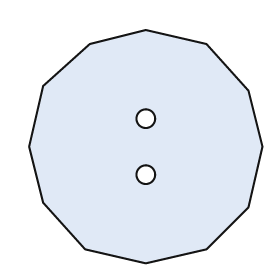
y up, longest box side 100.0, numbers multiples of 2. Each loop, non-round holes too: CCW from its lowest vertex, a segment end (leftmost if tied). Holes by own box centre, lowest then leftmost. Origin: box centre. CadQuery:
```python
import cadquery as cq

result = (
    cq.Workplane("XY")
    .moveTo(0.0, -50.0)
    .lineTo(26.0, -44.0)
    .lineTo(44.0, -26.0)
    .lineTo(50.0, 0.0)
    .lineTo(44.0, 24.0)
    .lineTo(26.0, 44.0)
    .lineTo(0.0, 50.0)
    .lineTo(-24.0, 44.0)
    .lineTo(-44.0, 26.0)
    .lineTo(-50.0, 0.0)
    .lineTo(-44.0, -24.0)
    .lineTo(-26.0, -44.0)
    .close()
    .moveTo(0.0, -12.0)
    .circle(4.0)
    .moveTo(0.0, 12.0)
    .circle(4.0)
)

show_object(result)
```